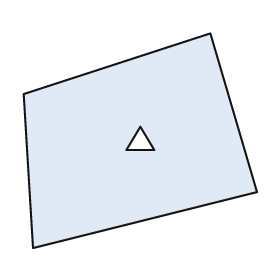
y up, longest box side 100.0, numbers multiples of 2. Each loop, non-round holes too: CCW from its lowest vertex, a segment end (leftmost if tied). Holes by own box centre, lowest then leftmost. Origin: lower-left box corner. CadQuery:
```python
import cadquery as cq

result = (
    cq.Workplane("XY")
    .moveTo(4.0, 0.0)
    .lineTo(100.0, 24.0)
    .lineTo(80.0, 92.0)
    .lineTo(0.0, 66.0)
    .close()
    .moveTo(44.0, 42.0)
    .lineTo(56.0, 42.0)
    .lineTo(50.0, 52.0)
    .close()
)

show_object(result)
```